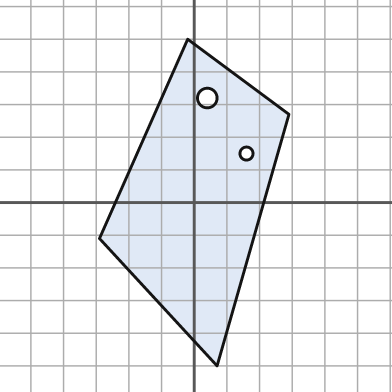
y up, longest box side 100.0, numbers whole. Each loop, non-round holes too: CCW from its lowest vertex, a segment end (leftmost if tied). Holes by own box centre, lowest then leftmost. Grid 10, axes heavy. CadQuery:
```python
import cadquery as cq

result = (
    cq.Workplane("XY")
    .moveTo(7.0, -50.0)
    .lineTo(29.0, 27.0)
    .lineTo(-2.0, 50.0)
    .lineTo(-29.0, -11.0)
    .close()
    .moveTo(16.0, 15.0)
    .circle(2.0)
    .moveTo(4.0, 32.0)
    .circle(3.0)
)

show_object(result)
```